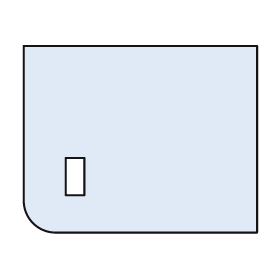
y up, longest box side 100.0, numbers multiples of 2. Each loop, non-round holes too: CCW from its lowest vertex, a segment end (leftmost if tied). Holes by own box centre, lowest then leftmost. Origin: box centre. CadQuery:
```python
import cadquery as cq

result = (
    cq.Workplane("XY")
    .moveTo(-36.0, -40.0)
    .lineTo(50.0, -40.0)
    .lineTo(50.0, 40.0)
    .lineTo(-50.0, 40.0)
    .lineTo(-50.0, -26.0)
    .threePointArc((-46.0, -36.0), (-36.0, -40.0))
    .close()
    .moveTo(-32.0, -24.0)
    .lineTo(-24.0, -24.0)
    .lineTo(-24.0, -8.0)
    .lineTo(-32.0, -8.0)
    .close()
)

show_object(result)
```